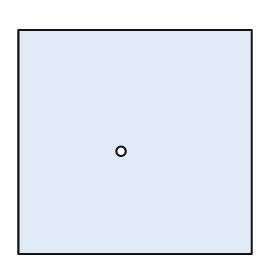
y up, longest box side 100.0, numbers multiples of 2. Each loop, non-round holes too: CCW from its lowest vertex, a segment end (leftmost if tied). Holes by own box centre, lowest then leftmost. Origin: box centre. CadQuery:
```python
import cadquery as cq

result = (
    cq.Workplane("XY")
    .moveTo(-50.0, -48.0)
    .lineTo(50.0, -48.0)
    .lineTo(50.0, 48.0)
    .lineTo(-50.0, 48.0)
    .close()
    .moveTo(-6.0, -4.0)
    .circle(2.0)
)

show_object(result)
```